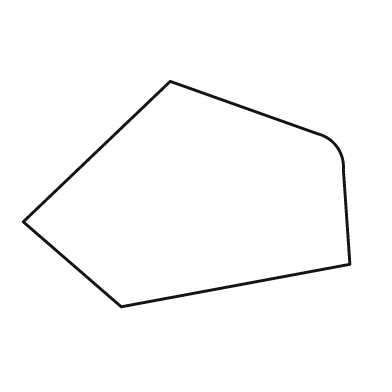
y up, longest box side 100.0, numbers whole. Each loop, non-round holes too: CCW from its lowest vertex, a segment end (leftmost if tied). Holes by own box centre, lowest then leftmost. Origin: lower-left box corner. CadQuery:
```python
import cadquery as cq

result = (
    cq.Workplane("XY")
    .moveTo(30.0, 0.0)
    .lineTo(100.0, 13.0)
    .lineTo(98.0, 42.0)
    .threePointArc((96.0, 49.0), (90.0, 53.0))
    .lineTo(45.0, 69.0)
    .lineTo(0.0, 26.0)
    .close()
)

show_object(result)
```